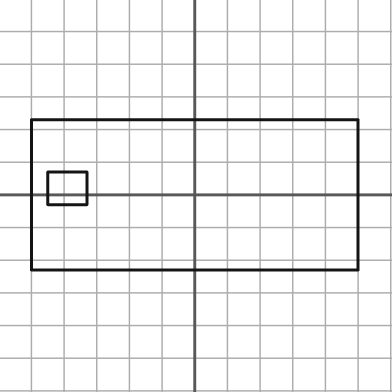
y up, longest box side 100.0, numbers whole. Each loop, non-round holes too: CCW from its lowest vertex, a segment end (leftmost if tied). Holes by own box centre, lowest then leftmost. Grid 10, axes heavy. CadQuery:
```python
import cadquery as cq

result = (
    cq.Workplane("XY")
    .moveTo(-50.0, -23.0)
    .lineTo(50.0, -23.0)
    .lineTo(50.0, 23.0)
    .lineTo(-50.0, 23.0)
    .close()
    .moveTo(-45.0, -3.0)
    .lineTo(-33.0, -3.0)
    .lineTo(-33.0, 7.0)
    .lineTo(-45.0, 7.0)
    .close()
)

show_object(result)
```